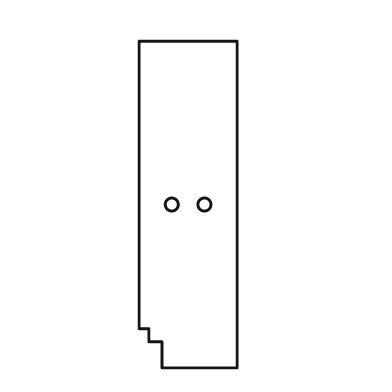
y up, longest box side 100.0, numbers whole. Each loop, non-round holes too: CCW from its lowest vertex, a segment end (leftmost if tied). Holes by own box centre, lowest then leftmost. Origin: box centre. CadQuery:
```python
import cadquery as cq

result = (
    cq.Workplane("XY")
    .moveTo(-8.0, -50.0)
    .lineTo(15.0, -50.0)
    .lineTo(15.0, 50.0)
    .lineTo(-15.0, 50.0)
    .lineTo(-15.0, -38.0)
    .lineTo(-12.0, -38.0)
    .lineTo(-12.0, -42.0)
    .lineTo(-8.0, -42.0)
    .close()
    .moveTo(-5.0, 0.0)
    .circle(2.0)
    .moveTo(5.0, 0.0)
    .circle(2.0)
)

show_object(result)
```